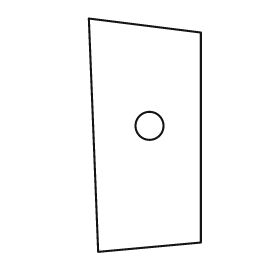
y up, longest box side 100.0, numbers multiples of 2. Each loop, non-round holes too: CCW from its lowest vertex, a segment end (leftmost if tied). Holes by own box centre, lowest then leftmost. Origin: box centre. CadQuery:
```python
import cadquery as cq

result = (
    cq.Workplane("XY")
    .moveTo(-20.0, -50.0)
    .lineTo(24.0, -46.0)
    .lineTo(24.0, 44.0)
    .lineTo(-24.0, 50.0)
    .close()
    .moveTo(2.0, 4.0)
    .circle(6.0)
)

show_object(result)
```